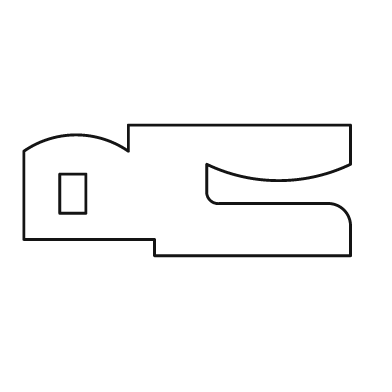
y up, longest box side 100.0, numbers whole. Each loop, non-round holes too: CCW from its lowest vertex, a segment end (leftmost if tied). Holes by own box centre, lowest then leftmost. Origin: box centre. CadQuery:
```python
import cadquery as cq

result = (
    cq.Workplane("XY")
    .moveTo(-10.0, -20.0)
    .lineTo(50.0, -20.0)
    .lineTo(50.0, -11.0)
    .threePointArc((48.0, -6.0), (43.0, -4.0))
    .lineTo(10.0, -4.0)
    .threePointArc((7.0, -3.0), (6.0, 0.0))
    .lineTo(6.0, 8.0)
    .threePointArc((28.0, 3.0), (50.0, 8.0))
    .lineTo(50.0, 20.0)
    .lineTo(-18.0, 20.0)
    .lineTo(-18.0, 12.0)
    .threePointArc((-34.0, 17.0), (-50.0, 12.0))
    .lineTo(-50.0, -15.0)
    .lineTo(-10.0, -15.0)
    .close()
    .moveTo(-39.0, -7.0)
    .lineTo(-31.0, -7.0)
    .lineTo(-31.0, 5.0)
    .lineTo(-39.0, 5.0)
    .close()
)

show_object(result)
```